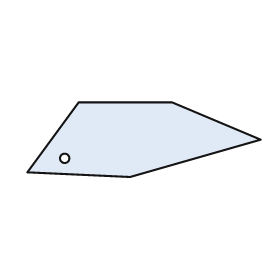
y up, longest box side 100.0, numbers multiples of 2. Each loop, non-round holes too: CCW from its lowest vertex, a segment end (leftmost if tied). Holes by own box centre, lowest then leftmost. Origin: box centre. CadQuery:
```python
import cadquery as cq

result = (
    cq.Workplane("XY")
    .moveTo(-6.0, -16.0)
    .lineTo(50.0, 0.0)
    .lineTo(12.0, 16.0)
    .lineTo(-28.0, 16.0)
    .lineTo(-50.0, -14.0)
    .close()
    .moveTo(-34.0, -8.0)
    .circle(2.0)
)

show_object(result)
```